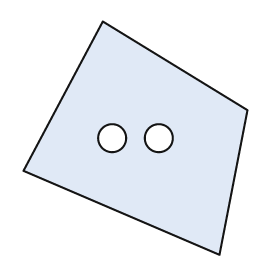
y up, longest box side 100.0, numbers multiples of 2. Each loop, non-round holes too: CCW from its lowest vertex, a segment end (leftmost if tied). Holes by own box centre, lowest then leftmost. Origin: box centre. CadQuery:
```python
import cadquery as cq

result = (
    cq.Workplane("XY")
    .moveTo(36.0, -50.0)
    .lineTo(48.0, 12.0)
    .lineTo(-14.0, 50.0)
    .lineTo(-48.0, -14.0)
    .close()
    .moveTo(-10.0, 0.0)
    .circle(6.0)
    .moveTo(10.0, 0.0)
    .circle(6.0)
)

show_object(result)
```